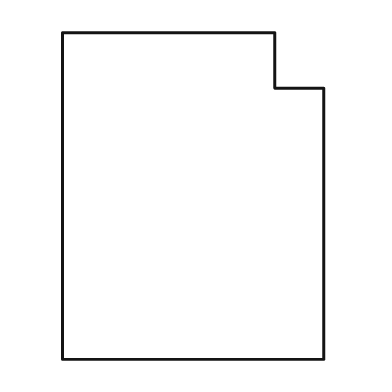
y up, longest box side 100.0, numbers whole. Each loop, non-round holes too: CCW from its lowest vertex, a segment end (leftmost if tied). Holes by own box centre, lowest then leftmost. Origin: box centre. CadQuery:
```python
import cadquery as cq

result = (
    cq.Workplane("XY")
    .moveTo(-40.0, -50.0)
    .lineTo(40.0, -50.0)
    .lineTo(40.0, 33.0)
    .lineTo(25.0, 33.0)
    .lineTo(25.0, 50.0)
    .lineTo(-40.0, 50.0)
    .close()
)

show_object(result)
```